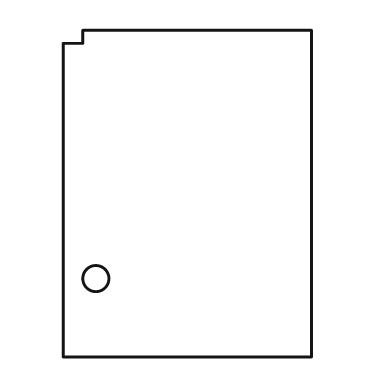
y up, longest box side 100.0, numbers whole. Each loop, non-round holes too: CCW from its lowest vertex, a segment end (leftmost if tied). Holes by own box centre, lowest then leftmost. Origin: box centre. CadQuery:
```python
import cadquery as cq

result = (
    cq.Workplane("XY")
    .moveTo(-38.0, -50.0)
    .lineTo(38.0, -50.0)
    .lineTo(38.0, 50.0)
    .lineTo(-32.0, 50.0)
    .lineTo(-32.0, 46.0)
    .lineTo(-38.0, 46.0)
    .close()
    .moveTo(-28.0, -26.0)
    .circle(4.0)
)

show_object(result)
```